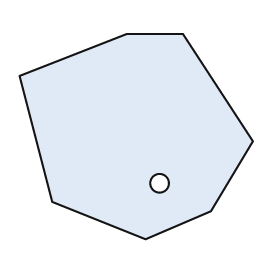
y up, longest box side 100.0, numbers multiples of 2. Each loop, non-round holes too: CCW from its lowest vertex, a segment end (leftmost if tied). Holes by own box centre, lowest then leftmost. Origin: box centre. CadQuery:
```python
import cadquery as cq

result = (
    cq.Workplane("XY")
    .moveTo(4.0, -44.0)
    .lineTo(32.0, -32.0)
    .lineTo(50.0, -2.0)
    .lineTo(20.0, 44.0)
    .lineTo(-4.0, 44.0)
    .lineTo(-50.0, 26.0)
    .lineTo(-36.0, -28.0)
    .close()
    .moveTo(10.0, -20.0)
    .circle(4.0)
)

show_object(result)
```